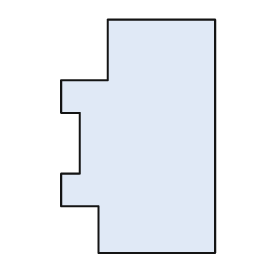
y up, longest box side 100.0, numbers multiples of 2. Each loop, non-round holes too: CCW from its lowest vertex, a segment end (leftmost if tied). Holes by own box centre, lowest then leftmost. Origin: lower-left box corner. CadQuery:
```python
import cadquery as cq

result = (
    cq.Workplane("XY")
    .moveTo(16.0, 0.0)
    .lineTo(66.0, 0.0)
    .lineTo(66.0, 100.0)
    .lineTo(20.0, 100.0)
    .lineTo(20.0, 74.0)
    .lineTo(0.0, 74.0)
    .lineTo(0.0, 60.0)
    .lineTo(8.0, 60.0)
    .lineTo(8.0, 34.0)
    .lineTo(0.0, 34.0)
    .lineTo(0.0, 20.0)
    .lineTo(16.0, 20.0)
    .close()
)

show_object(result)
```